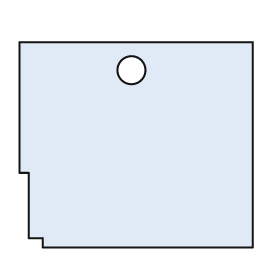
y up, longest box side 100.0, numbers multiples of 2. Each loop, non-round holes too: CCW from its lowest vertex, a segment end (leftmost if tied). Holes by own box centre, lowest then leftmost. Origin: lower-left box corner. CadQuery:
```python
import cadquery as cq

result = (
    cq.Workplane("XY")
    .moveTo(10.0, 0.0)
    .lineTo(100.0, 0.0)
    .lineTo(100.0, 88.0)
    .lineTo(0.0, 88.0)
    .lineTo(0.0, 32.0)
    .lineTo(4.0, 32.0)
    .lineTo(4.0, 4.0)
    .lineTo(10.0, 4.0)
    .close()
    .moveTo(48.0, 76.0)
    .circle(6.0)
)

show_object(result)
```